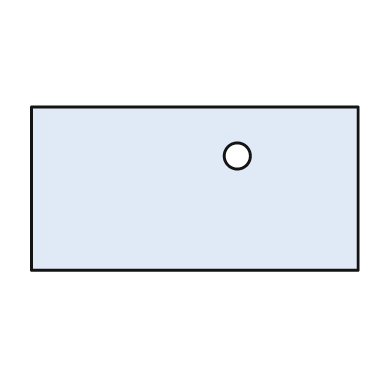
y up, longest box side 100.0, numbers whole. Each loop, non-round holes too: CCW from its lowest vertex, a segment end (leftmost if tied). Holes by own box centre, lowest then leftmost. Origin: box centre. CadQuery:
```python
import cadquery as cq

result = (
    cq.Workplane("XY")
    .moveTo(-50.0, -25.0)
    .lineTo(50.0, -25.0)
    .lineTo(50.0, 25.0)
    .lineTo(-50.0, 25.0)
    .close()
    .moveTo(13.0, 10.0)
    .circle(4.0)
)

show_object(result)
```